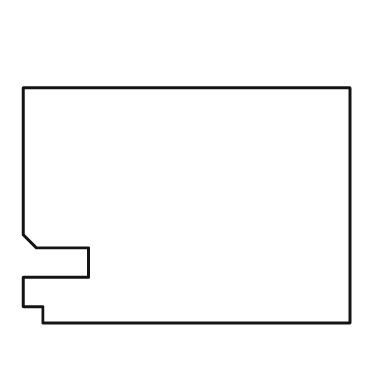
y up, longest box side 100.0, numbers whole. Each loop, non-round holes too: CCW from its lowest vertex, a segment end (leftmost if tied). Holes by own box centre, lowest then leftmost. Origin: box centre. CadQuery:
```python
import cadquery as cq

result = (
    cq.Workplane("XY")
    .moveTo(-44.0, -36.0)
    .lineTo(50.0, -36.0)
    .lineTo(50.0, 36.0)
    .lineTo(-50.0, 36.0)
    .lineTo(-50.0, -9.0)
    .lineTo(-46.0, -13.0)
    .lineTo(-30.0, -13.0)
    .lineTo(-30.0, -22.0)
    .lineTo(-50.0, -22.0)
    .lineTo(-50.0, -31.0)
    .lineTo(-44.0, -31.0)
    .close()
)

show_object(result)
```